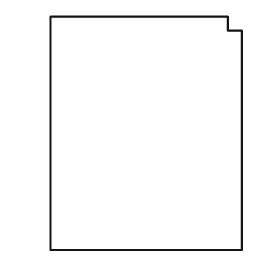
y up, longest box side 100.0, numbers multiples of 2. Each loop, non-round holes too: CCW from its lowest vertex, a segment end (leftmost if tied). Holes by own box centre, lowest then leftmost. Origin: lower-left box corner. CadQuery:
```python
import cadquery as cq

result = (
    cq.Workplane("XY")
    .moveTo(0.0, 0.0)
    .lineTo(82.0, 0.0)
    .lineTo(82.0, 94.0)
    .lineTo(76.0, 94.0)
    .lineTo(76.0, 100.0)
    .lineTo(0.0, 100.0)
    .close()
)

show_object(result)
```